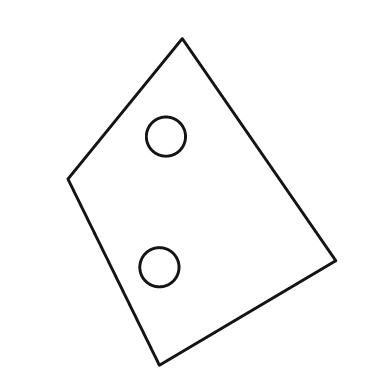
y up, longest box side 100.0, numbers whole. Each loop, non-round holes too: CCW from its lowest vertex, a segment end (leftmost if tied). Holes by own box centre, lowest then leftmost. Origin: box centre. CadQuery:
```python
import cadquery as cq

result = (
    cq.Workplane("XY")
    .moveTo(-13.0, -50.0)
    .lineTo(41.0, -18.0)
    .lineTo(-6.0, 50.0)
    .lineTo(-41.0, 7.0)
    .close()
    .moveTo(-13.0, -20.0)
    .circle(6.0)
    .moveTo(-11.0, 20.0)
    .circle(6.0)
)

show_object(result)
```